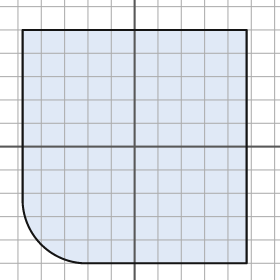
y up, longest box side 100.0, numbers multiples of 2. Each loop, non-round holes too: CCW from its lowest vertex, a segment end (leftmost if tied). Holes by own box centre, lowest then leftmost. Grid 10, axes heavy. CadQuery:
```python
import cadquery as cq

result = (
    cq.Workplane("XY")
    .moveTo(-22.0, -50.0)
    .lineTo(48.0, -50.0)
    .lineTo(48.0, 50.0)
    .lineTo(-48.0, 50.0)
    .lineTo(-48.0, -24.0)
    .threePointArc((-40.0, -42.0), (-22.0, -50.0))
    .close()
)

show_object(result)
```